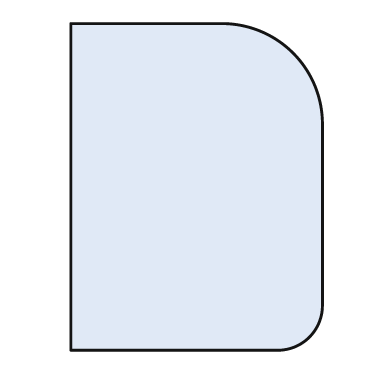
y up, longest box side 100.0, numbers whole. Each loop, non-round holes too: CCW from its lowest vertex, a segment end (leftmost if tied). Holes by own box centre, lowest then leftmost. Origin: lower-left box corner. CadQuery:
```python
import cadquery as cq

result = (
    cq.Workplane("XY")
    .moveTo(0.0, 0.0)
    .lineTo(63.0, 0.0)
    .threePointArc((73.0, 4.0), (77.0, 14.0))
    .lineTo(77.0, 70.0)
    .threePointArc((68.0, 91.0), (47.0, 100.0))
    .lineTo(0.0, 100.0)
    .close()
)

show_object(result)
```